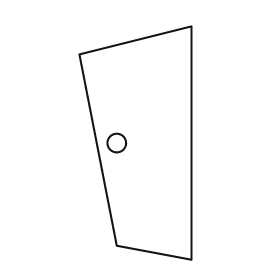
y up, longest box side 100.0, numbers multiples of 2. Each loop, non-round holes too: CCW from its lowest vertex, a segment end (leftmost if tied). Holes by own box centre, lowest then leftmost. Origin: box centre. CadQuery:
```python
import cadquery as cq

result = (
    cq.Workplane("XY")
    .moveTo(24.0, -50.0)
    .lineTo(24.0, 50.0)
    .lineTo(-24.0, 38.0)
    .lineTo(-8.0, -44.0)
    .close()
    .moveTo(-8.0, 0.0)
    .circle(4.0)
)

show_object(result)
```